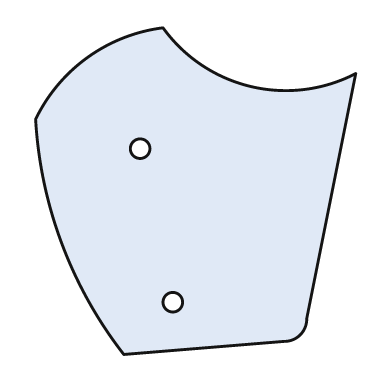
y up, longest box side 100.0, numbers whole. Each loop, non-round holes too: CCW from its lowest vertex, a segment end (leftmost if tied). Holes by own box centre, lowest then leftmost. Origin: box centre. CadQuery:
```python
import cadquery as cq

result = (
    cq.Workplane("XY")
    .moveTo(-22.0, -50.0)
    .lineTo(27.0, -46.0)
    .threePointArc((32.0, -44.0), (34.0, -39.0))
    .lineTo(49.0, 36.0)
    .threePointArc((17.0, 32.0), (-10.0, 50.0))
    .threePointArc((-33.0, 41.0), (-49.0, 22.0))
    .threePointArc((-41.0, -16.0), (-22.0, -50.0))
    .close()
    .moveTo(-7.0, -34.0)
    .circle(3.0)
    .moveTo(-17.0, 13.0)
    .circle(3.0)
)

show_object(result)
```